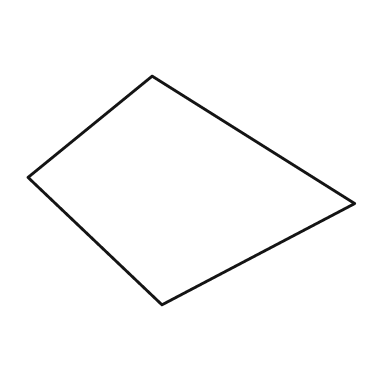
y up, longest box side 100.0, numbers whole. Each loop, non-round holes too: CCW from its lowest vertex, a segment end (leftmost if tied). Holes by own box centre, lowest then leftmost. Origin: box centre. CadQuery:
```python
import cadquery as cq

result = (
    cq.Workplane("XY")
    .moveTo(-9.0, -35.0)
    .lineTo(50.0, -4.0)
    .lineTo(-12.0, 35.0)
    .lineTo(-50.0, 4.0)
    .close()
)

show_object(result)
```